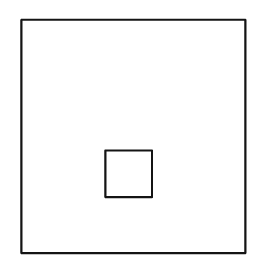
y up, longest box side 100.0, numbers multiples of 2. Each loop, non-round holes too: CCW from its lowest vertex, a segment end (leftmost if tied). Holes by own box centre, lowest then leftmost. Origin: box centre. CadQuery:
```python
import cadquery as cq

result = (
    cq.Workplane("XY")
    .moveTo(-48.0, -50.0)
    .lineTo(48.0, -50.0)
    .lineTo(48.0, 50.0)
    .lineTo(-48.0, 50.0)
    .close()
    .moveTo(-12.0, -26.0)
    .lineTo(8.0, -26.0)
    .lineTo(8.0, -6.0)
    .lineTo(-12.0, -6.0)
    .close()
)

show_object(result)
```